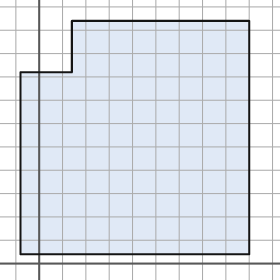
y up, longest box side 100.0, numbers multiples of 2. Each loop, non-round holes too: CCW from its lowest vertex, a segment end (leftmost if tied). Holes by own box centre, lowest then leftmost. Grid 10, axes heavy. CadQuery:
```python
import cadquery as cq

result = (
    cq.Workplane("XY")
    .moveTo(-8.0, 4.0)
    .lineTo(90.0, 4.0)
    .lineTo(90.0, 104.0)
    .lineTo(14.0, 104.0)
    .lineTo(14.0, 82.0)
    .lineTo(-8.0, 82.0)
    .close()
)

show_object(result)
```